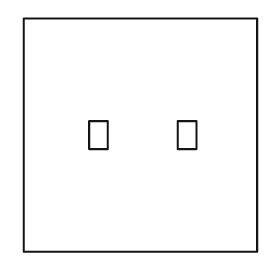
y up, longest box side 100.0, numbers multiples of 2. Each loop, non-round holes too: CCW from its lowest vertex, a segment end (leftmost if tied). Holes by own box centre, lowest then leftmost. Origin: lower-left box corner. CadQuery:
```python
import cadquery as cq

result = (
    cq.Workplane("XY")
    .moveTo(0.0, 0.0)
    .lineTo(100.0, 0.0)
    .lineTo(100.0, 100.0)
    .lineTo(0.0, 100.0)
    .close()
    .moveTo(28.0, 44.0)
    .lineTo(36.0, 44.0)
    .lineTo(36.0, 56.0)
    .lineTo(28.0, 56.0)
    .close()
    .moveTo(66.0, 44.0)
    .lineTo(74.0, 44.0)
    .lineTo(74.0, 56.0)
    .lineTo(66.0, 56.0)
    .close()
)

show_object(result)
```